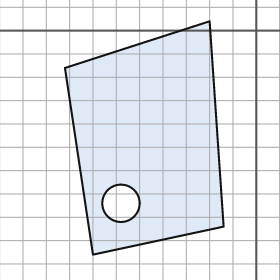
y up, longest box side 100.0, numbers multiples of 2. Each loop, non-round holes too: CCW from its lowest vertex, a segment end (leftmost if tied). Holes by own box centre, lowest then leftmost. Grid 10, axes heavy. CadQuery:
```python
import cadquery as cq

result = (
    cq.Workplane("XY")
    .moveTo(-70.0, -96.0)
    .lineTo(-14.0, -84.0)
    .lineTo(-20.0, 4.0)
    .lineTo(-82.0, -16.0)
    .close()
    .moveTo(-58.0, -74.0)
    .circle(8.0)
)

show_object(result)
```